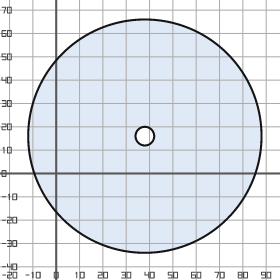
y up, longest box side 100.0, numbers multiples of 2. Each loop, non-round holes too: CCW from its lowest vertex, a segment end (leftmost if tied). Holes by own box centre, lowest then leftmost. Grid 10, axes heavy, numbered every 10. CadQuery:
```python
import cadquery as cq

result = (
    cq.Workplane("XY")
    .moveTo(38.0, 16.0)
    .circle(50.0)
    .moveTo(38.0, 16.0)
    .circle(4.0)
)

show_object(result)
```